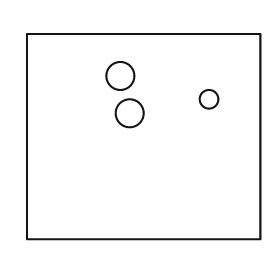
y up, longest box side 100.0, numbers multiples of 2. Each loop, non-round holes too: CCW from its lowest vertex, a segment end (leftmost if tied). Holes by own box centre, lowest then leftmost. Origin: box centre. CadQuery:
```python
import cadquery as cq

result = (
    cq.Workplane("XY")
    .moveTo(-50.0, -44.0)
    .lineTo(50.0, -44.0)
    .lineTo(50.0, 44.0)
    .lineTo(-50.0, 44.0)
    .close()
    .moveTo(-6.0, 10.0)
    .circle(6.0)
    .moveTo(28.0, 16.0)
    .circle(4.0)
    .moveTo(-10.0, 26.0)
    .circle(6.0)
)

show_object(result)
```